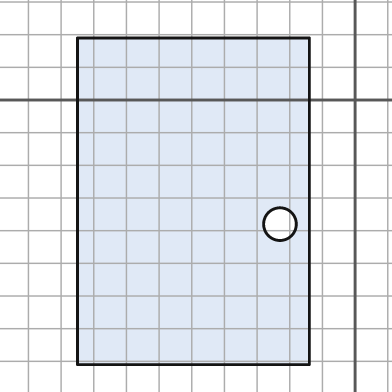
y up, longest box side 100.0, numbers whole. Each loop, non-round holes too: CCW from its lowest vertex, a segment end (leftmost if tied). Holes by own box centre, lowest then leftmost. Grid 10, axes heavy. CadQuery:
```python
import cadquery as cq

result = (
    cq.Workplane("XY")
    .moveTo(-85.0, -81.0)
    .lineTo(-14.0, -81.0)
    .lineTo(-14.0, 19.0)
    .lineTo(-85.0, 19.0)
    .close()
    .moveTo(-23.0, -38.0)
    .circle(5.0)
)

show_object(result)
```